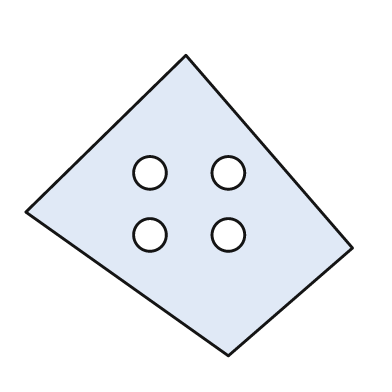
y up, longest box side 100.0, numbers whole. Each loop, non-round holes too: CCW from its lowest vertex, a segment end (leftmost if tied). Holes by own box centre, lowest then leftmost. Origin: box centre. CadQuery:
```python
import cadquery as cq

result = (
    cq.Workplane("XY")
    .moveTo(12.0, -46.0)
    .lineTo(50.0, -13.0)
    .lineTo(-1.0, 46.0)
    .lineTo(-50.0, -2.0)
    .close()
    .moveTo(-12.0, -9.0)
    .circle(5.0)
    .moveTo(12.0, -9.0)
    .circle(5.0)
    .moveTo(-12.0, 10.0)
    .circle(5.0)
    .moveTo(12.0, 10.0)
    .circle(5.0)
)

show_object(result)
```